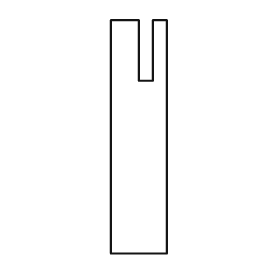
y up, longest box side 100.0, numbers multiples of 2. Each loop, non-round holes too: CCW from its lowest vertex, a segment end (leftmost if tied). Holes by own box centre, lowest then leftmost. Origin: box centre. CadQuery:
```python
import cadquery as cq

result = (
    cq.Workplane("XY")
    .moveTo(-12.0, -50.0)
    .lineTo(12.0, -50.0)
    .lineTo(12.0, 50.0)
    .lineTo(6.0, 50.0)
    .lineTo(6.0, 24.0)
    .lineTo(0.0, 24.0)
    .lineTo(0.0, 50.0)
    .lineTo(-12.0, 50.0)
    .close()
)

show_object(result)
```